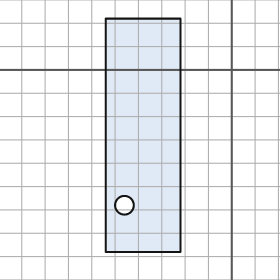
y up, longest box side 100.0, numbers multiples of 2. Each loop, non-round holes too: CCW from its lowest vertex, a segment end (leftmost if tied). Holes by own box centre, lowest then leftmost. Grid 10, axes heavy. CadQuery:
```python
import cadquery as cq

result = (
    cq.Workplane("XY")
    .moveTo(-54.0, -78.0)
    .lineTo(-22.0, -78.0)
    .lineTo(-22.0, 22.0)
    .lineTo(-54.0, 22.0)
    .close()
    .moveTo(-46.0, -58.0)
    .circle(4.0)
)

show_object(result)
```